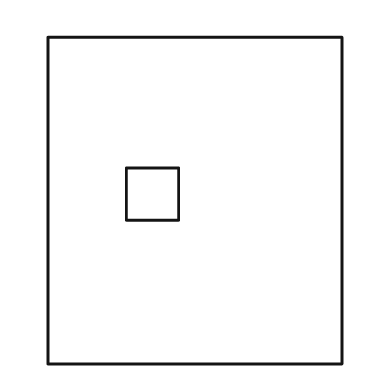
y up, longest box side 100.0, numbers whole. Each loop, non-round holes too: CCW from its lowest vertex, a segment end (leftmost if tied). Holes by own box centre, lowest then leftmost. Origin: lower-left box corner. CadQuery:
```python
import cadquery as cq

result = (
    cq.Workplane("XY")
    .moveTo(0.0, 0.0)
    .lineTo(90.0, 0.0)
    .lineTo(90.0, 100.0)
    .lineTo(0.0, 100.0)
    .close()
    .moveTo(24.0, 44.0)
    .lineTo(40.0, 44.0)
    .lineTo(40.0, 60.0)
    .lineTo(24.0, 60.0)
    .close()
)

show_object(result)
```